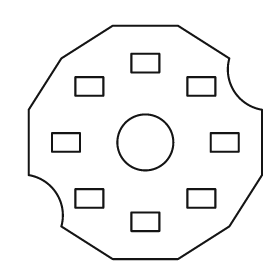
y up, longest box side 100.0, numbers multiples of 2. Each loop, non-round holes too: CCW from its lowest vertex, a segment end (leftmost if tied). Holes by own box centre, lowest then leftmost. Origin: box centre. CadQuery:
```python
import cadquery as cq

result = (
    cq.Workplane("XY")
    .moveTo(-14.0, -50.0)
    .lineTo(14.0, -50.0)
    .lineTo(36.0, -36.0)
    .lineTo(50.0, -14.0)
    .lineTo(50.0, 14.0)
    .threePointArc((38.0, 22.0), (36.0, 36.0))
    .lineTo(14.0, 50.0)
    .lineTo(-14.0, 50.0)
    .lineTo(-36.0, 36.0)
    .lineTo(-50.0, 14.0)
    .lineTo(-50.0, -14.0)
    .threePointArc((-38.0, -22.0), (-36.0, -36.0))
    .close()
    .moveTo(-6.0, -38.0)
    .lineTo(6.0, -38.0)
    .lineTo(6.0, -30.0)
    .lineTo(-6.0, -30.0)
    .close()
    .moveTo(-30.0, -28.0)
    .lineTo(-18.0, -28.0)
    .lineTo(-18.0, -20.0)
    .lineTo(-30.0, -20.0)
    .close()
    .moveTo(18.0, -28.0)
    .lineTo(30.0, -28.0)
    .lineTo(30.0, -20.0)
    .lineTo(18.0, -20.0)
    .close()
    .moveTo(-40.0, -4.0)
    .lineTo(-28.0, -4.0)
    .lineTo(-28.0, 4.0)
    .lineTo(-40.0, 4.0)
    .close()
    .moveTo(0.0, 0.0)
    .circle(12.0)
    .moveTo(28.0, -4.0)
    .lineTo(40.0, -4.0)
    .lineTo(40.0, 4.0)
    .lineTo(28.0, 4.0)
    .close()
    .moveTo(-30.0, 20.0)
    .lineTo(-18.0, 20.0)
    .lineTo(-18.0, 28.0)
    .lineTo(-30.0, 28.0)
    .close()
    .moveTo(18.0, 20.0)
    .lineTo(30.0, 20.0)
    .lineTo(30.0, 28.0)
    .lineTo(18.0, 28.0)
    .close()
    .moveTo(-6.0, 30.0)
    .lineTo(6.0, 30.0)
    .lineTo(6.0, 38.0)
    .lineTo(-6.0, 38.0)
    .close()
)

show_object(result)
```